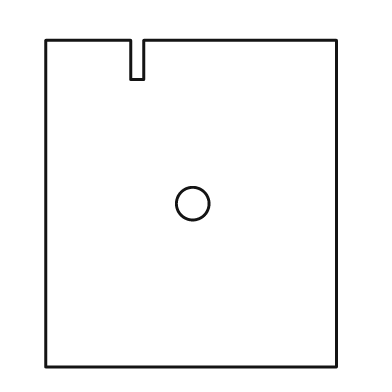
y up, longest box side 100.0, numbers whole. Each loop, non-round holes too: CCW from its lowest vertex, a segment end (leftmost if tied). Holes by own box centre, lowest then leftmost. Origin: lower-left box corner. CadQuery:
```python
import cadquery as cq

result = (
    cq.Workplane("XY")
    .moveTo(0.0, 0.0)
    .lineTo(89.0, 0.0)
    .lineTo(89.0, 100.0)
    .lineTo(30.0, 100.0)
    .lineTo(30.0, 88.0)
    .lineTo(26.0, 88.0)
    .lineTo(26.0, 100.0)
    .lineTo(0.0, 100.0)
    .close()
    .moveTo(45.0, 50.0)
    .circle(5.0)
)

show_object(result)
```